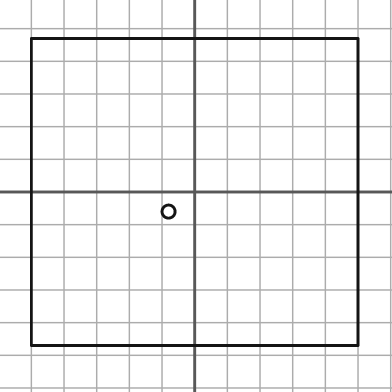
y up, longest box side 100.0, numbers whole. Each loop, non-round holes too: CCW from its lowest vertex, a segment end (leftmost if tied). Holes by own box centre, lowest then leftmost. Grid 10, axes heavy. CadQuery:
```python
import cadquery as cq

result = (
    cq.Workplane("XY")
    .moveTo(-50.0, -47.0)
    .lineTo(50.0, -47.0)
    .lineTo(50.0, 47.0)
    .lineTo(-50.0, 47.0)
    .close()
    .moveTo(-8.0, -6.0)
    .circle(2.0)
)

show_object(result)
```